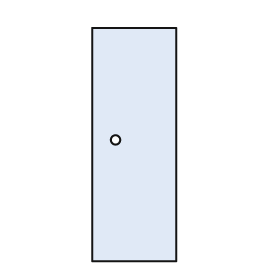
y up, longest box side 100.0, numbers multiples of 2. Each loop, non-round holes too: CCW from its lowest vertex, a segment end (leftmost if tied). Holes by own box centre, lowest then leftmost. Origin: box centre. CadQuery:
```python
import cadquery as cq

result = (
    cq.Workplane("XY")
    .moveTo(-18.0, -50.0)
    .lineTo(18.0, -50.0)
    .lineTo(18.0, 50.0)
    .lineTo(-18.0, 50.0)
    .close()
    .moveTo(-8.0, 2.0)
    .circle(2.0)
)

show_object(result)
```